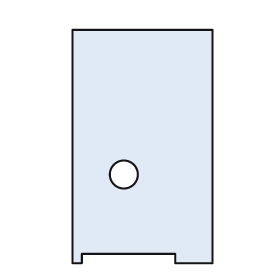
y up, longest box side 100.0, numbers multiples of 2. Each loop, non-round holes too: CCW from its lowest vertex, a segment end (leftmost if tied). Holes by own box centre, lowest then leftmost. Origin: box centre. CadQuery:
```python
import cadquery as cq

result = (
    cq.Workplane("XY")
    .moveTo(-30.0, -50.0)
    .lineTo(-26.0, -50.0)
    .lineTo(-26.0, -46.0)
    .lineTo(14.0, -46.0)
    .lineTo(14.0, -50.0)
    .lineTo(30.0, -50.0)
    .lineTo(30.0, 50.0)
    .lineTo(-30.0, 50.0)
    .close()
    .moveTo(-8.0, -12.0)
    .circle(6.0)
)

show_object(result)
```